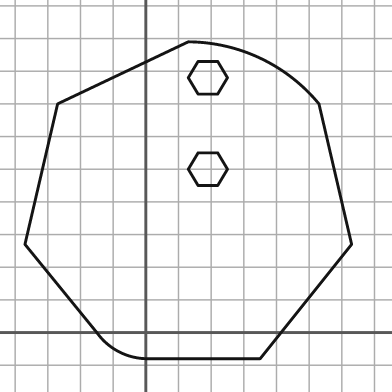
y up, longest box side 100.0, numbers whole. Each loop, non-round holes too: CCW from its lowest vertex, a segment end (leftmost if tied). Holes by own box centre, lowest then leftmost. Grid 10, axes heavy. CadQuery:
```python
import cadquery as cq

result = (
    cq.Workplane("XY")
    .moveTo(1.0, -8.0)
    .lineTo(35.0, -8.0)
    .lineTo(63.0, 27.0)
    .lineTo(53.0, 70.0)
    .threePointArc((35.0, 84.0), (13.0, 89.0))
    .lineTo(-27.0, 70.0)
    .lineTo(-37.0, 27.0)
    .lineTo(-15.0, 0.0)
    .threePointArc((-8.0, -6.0), (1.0, -8.0))
    .close()
    .moveTo(16.0, 45.0)
    .lineTo(22.0, 45.0)
    .lineTo(25.0, 50.0)
    .lineTo(22.0, 55.0)
    .lineTo(16.0, 55.0)
    .lineTo(13.0, 50.0)
    .close()
    .moveTo(16.0, 73.0)
    .lineTo(22.0, 73.0)
    .lineTo(25.0, 78.0)
    .lineTo(22.0, 83.0)
    .lineTo(16.0, 83.0)
    .lineTo(13.0, 78.0)
    .close()
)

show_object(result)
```